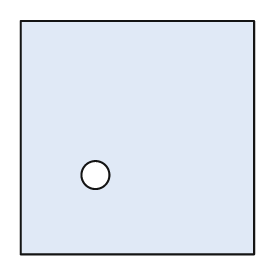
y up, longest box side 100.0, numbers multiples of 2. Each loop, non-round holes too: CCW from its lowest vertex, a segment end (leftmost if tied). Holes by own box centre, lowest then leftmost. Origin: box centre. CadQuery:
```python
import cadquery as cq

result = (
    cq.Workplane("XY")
    .moveTo(-50.0, -50.0)
    .lineTo(50.0, -50.0)
    .lineTo(50.0, 50.0)
    .lineTo(-50.0, 50.0)
    .close()
    .moveTo(-18.0, -16.0)
    .circle(6.0)
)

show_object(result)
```